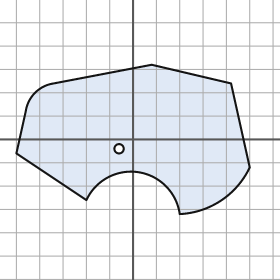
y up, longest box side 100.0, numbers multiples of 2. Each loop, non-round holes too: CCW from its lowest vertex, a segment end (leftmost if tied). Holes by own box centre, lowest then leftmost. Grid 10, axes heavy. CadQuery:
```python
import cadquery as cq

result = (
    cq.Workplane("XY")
    .moveTo(20.0, -32.0)
    .threePointArc((38.0, -26.0), (50.0, -12.0))
    .lineTo(42.0, 24.0)
    .lineTo(8.0, 32.0)
    .lineTo(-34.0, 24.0)
    .threePointArc((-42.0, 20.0), (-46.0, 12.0))
    .lineTo(-50.0, -6.0)
    .lineTo(-20.0, -26.0)
    .threePointArc((2.0, -14.0), (20.0, -32.0))
    .close()
    .moveTo(-6.0, -4.0)
    .circle(2.0)
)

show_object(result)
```